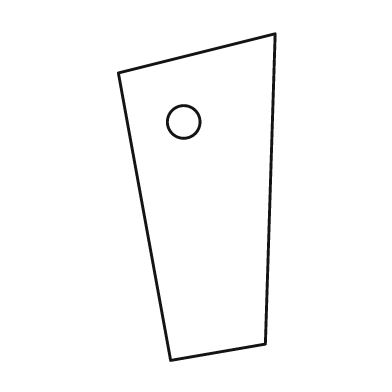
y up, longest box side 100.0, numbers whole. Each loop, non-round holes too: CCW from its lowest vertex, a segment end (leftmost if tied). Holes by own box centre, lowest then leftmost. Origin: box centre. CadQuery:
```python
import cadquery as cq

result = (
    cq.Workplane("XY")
    .moveTo(-8.0, -50.0)
    .lineTo(21.0, -45.0)
    .lineTo(24.0, 50.0)
    .lineTo(-24.0, 38.0)
    .close()
    .moveTo(-4.0, 23.0)
    .circle(5.0)
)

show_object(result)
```